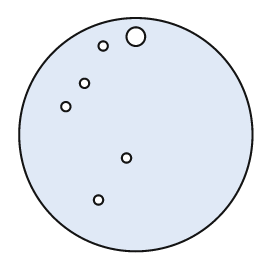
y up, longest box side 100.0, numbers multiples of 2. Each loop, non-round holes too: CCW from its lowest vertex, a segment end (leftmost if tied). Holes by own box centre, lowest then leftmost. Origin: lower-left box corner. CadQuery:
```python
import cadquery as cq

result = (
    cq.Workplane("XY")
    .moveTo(50.0, 50.0)
    .circle(50.0)
    .moveTo(34.0, 22.0)
    .circle(2.0)
    .moveTo(46.0, 40.0)
    .circle(2.0)
    .moveTo(20.0, 62.0)
    .circle(2.0)
    .moveTo(28.0, 72.0)
    .circle(2.0)
    .moveTo(36.0, 88.0)
    .circle(2.0)
    .moveTo(50.0, 92.0)
    .circle(4.0)
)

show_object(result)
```